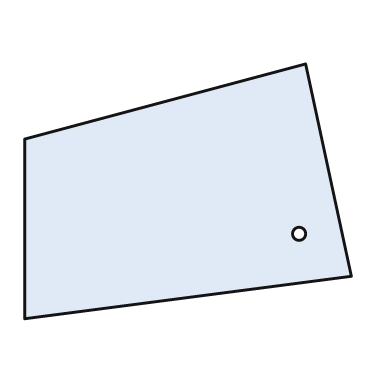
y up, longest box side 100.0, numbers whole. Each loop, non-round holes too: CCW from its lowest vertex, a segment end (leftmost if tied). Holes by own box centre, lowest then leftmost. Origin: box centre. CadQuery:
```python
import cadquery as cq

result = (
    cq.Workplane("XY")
    .moveTo(-50.0, -39.0)
    .lineTo(50.0, -26.0)
    .lineTo(36.0, 39.0)
    .lineTo(-50.0, 16.0)
    .close()
    .moveTo(34.0, -13.0)
    .circle(2.0)
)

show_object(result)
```